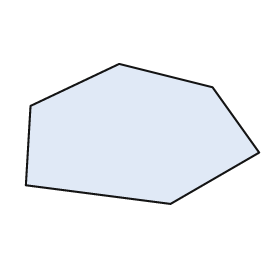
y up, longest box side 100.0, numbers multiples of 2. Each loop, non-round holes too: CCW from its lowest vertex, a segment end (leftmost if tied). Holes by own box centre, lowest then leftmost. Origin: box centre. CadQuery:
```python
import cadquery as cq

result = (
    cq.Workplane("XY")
    .moveTo(12.0, -30.0)
    .lineTo(50.0, -8.0)
    .lineTo(30.0, 20.0)
    .lineTo(-10.0, 30.0)
    .lineTo(-48.0, 12.0)
    .lineTo(-50.0, -22.0)
    .close()
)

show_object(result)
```